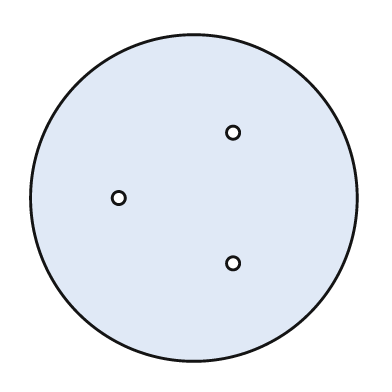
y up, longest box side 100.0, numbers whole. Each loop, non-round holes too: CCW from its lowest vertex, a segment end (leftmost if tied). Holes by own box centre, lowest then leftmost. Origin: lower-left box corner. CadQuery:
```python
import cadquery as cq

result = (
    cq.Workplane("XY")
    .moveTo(50.0, 50.0)
    .circle(50.0)
    .moveTo(62.0, 30.0)
    .circle(2.0)
    .moveTo(27.0, 50.0)
    .circle(2.0)
    .moveTo(62.0, 70.0)
    .circle(2.0)
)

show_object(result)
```